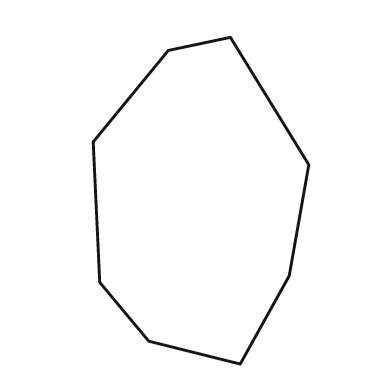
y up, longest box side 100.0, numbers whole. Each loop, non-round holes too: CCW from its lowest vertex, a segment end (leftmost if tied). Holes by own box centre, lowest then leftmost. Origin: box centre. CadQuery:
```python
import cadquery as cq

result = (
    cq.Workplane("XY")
    .moveTo(12.0, -50.0)
    .lineTo(27.0, -23.0)
    .lineTo(33.0, 11.0)
    .lineTo(9.0, 50.0)
    .lineTo(-10.0, 46.0)
    .lineTo(-33.0, 18.0)
    .lineTo(-31.0, -25.0)
    .lineTo(-16.0, -43.0)
    .close()
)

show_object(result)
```